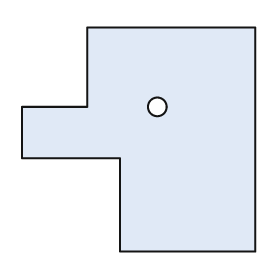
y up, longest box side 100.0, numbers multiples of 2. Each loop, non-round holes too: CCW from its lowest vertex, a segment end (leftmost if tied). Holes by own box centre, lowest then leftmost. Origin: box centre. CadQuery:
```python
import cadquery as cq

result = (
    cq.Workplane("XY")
    .moveTo(-8.0, -48.0)
    .lineTo(50.0, -48.0)
    .lineTo(50.0, 48.0)
    .lineTo(-22.0, 48.0)
    .lineTo(-22.0, 14.0)
    .lineTo(-50.0, 14.0)
    .lineTo(-50.0, -8.0)
    .lineTo(-8.0, -8.0)
    .close()
    .moveTo(8.0, 14.0)
    .circle(4.0)
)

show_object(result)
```